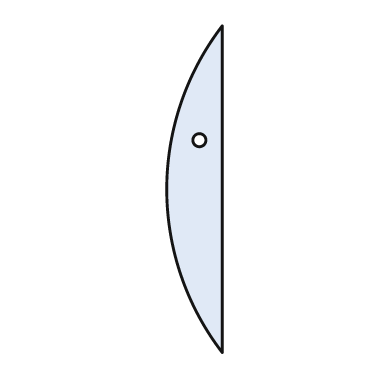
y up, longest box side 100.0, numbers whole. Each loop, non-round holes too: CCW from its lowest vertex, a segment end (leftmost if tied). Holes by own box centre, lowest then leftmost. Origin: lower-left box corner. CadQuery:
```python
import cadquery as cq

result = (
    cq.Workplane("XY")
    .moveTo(17.0, 0.0)
    .lineTo(17.0, 100.0)
    .threePointArc((0.0, 50.0), (17.0, 0.0))
    .close()
    .moveTo(10.0, 65.0)
    .circle(2.0)
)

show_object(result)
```